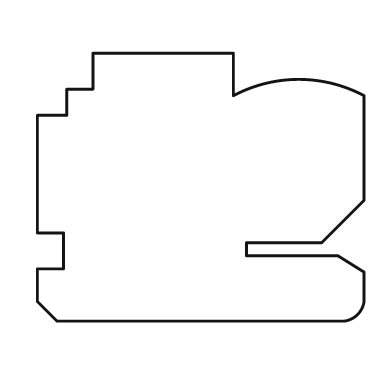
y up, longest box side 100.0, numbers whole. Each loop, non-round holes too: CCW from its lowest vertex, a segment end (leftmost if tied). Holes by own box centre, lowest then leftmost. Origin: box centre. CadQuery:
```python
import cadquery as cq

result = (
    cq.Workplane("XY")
    .moveTo(-44.0, -41.0)
    .lineTo(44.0, -41.0)
    .threePointArc((48.0, -39.0), (50.0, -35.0))
    .lineTo(50.0, -26.0)
    .lineTo(42.0, -21.0)
    .lineTo(14.0, -21.0)
    .lineTo(14.0, -17.0)
    .lineTo(37.0, -17.0)
    .lineTo(50.0, -4.0)
    .lineTo(50.0, 28.0)
    .threePointArc((30.0, 33.0), (10.0, 28.0))
    .lineTo(10.0, 41.0)
    .lineTo(-33.0, 41.0)
    .lineTo(-33.0, 30.0)
    .lineTo(-41.0, 30.0)
    .lineTo(-41.0, 22.0)
    .lineTo(-50.0, 22.0)
    .lineTo(-50.0, -14.0)
    .lineTo(-42.0, -14.0)
    .lineTo(-42.0, -25.0)
    .lineTo(-50.0, -25.0)
    .lineTo(-50.0, -35.0)
    .close()
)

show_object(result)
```